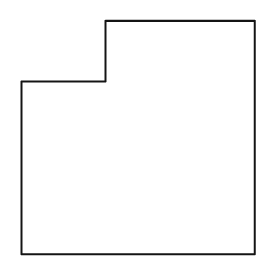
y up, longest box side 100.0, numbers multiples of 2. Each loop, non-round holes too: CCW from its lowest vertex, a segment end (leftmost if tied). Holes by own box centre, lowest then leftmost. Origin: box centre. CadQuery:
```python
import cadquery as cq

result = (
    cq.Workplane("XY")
    .moveTo(-50.0, -50.0)
    .lineTo(50.0, -50.0)
    .lineTo(50.0, 50.0)
    .lineTo(-14.0, 50.0)
    .lineTo(-14.0, 24.0)
    .lineTo(-50.0, 24.0)
    .close()
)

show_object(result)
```